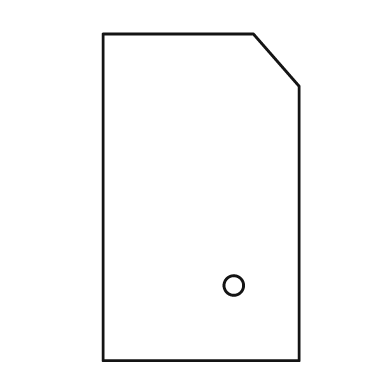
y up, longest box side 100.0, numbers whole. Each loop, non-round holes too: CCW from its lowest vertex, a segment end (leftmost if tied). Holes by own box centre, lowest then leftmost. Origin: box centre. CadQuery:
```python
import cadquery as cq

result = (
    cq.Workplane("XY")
    .moveTo(-30.0, -50.0)
    .lineTo(30.0, -50.0)
    .lineTo(30.0, 34.0)
    .lineTo(16.0, 50.0)
    .lineTo(-30.0, 50.0)
    .close()
    .moveTo(10.0, -27.0)
    .circle(3.0)
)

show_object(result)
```